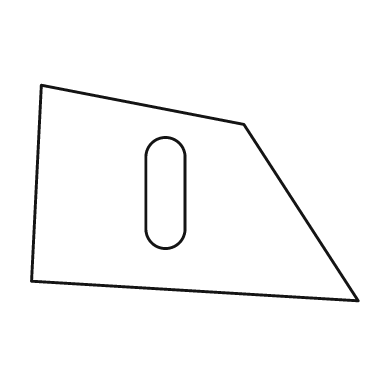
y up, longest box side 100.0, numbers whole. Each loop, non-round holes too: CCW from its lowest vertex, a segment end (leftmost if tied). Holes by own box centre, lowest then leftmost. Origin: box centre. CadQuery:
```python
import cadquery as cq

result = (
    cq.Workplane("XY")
    .moveTo(50.0, -33.0)
    .lineTo(15.0, 21.0)
    .lineTo(-47.0, 33.0)
    .lineTo(-50.0, -27.0)
    .close()
    .moveTo(-15.0, -11.0)
    .threePointArc((-9.0, -17.0), (-3.0, -11.0))
    .lineTo(-3.0, 11.0)
    .threePointArc((-9.0, 17.0), (-15.0, 11.0))
    .close()
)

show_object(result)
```